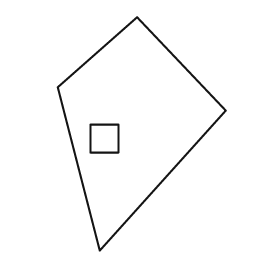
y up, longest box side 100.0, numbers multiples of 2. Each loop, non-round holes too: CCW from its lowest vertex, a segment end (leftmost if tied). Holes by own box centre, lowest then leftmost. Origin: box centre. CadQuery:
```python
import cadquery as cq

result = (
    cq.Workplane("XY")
    .moveTo(-18.0, -50.0)
    .lineTo(36.0, 10.0)
    .lineTo(-2.0, 50.0)
    .lineTo(-36.0, 20.0)
    .close()
    .moveTo(-22.0, -8.0)
    .lineTo(-10.0, -8.0)
    .lineTo(-10.0, 4.0)
    .lineTo(-22.0, 4.0)
    .close()
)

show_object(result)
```